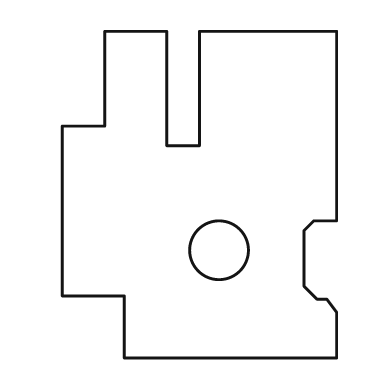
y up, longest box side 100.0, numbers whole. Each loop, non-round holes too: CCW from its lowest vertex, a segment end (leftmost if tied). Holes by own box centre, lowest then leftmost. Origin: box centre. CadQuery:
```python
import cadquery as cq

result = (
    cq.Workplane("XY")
    .moveTo(-23.0, -50.0)
    .lineTo(42.0, -50.0)
    .lineTo(42.0, -36.0)
    .lineTo(39.0, -32.0)
    .lineTo(36.0, -32.0)
    .lineTo(32.0, -28.0)
    .lineTo(32.0, -11.0)
    .lineTo(35.0, -8.0)
    .lineTo(42.0, -8.0)
    .lineTo(42.0, 50.0)
    .lineTo(0.0, 50.0)
    .lineTo(0.0, 15.0)
    .lineTo(-10.0, 15.0)
    .lineTo(-10.0, 50.0)
    .lineTo(-29.0, 50.0)
    .lineTo(-29.0, 21.0)
    .lineTo(-42.0, 21.0)
    .lineTo(-42.0, -31.0)
    .lineTo(-23.0, -31.0)
    .close()
    .moveTo(6.0, -17.0)
    .circle(9.0)
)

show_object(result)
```